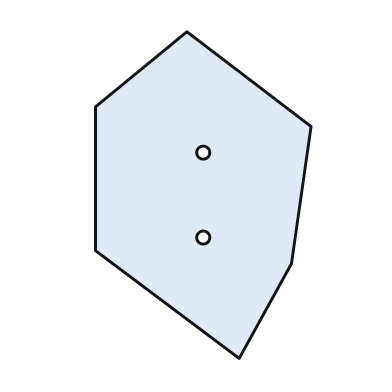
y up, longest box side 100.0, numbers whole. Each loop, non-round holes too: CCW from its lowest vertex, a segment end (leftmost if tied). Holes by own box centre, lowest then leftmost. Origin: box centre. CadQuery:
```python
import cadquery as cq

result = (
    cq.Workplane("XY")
    .moveTo(11.0, -50.0)
    .lineTo(27.0, -21.0)
    .lineTo(33.0, 21.0)
    .lineTo(-5.0, 50.0)
    .lineTo(-33.0, 27.0)
    .lineTo(-33.0, -17.0)
    .close()
    .moveTo(0.0, -13.0)
    .circle(2.0)
    .moveTo(0.0, 13.0)
    .circle(2.0)
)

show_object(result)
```